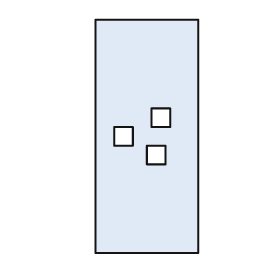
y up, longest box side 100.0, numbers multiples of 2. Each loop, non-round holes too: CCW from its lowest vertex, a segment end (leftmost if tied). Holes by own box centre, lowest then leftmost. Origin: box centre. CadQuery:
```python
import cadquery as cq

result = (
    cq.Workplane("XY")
    .moveTo(-22.0, -50.0)
    .lineTo(22.0, -50.0)
    .lineTo(22.0, 50.0)
    .lineTo(-22.0, 50.0)
    .close()
    .moveTo(0.0, -12.0)
    .lineTo(8.0, -12.0)
    .lineTo(8.0, -4.0)
    .lineTo(0.0, -4.0)
    .close()
    .moveTo(-14.0, -4.0)
    .lineTo(-6.0, -4.0)
    .lineTo(-6.0, 4.0)
    .lineTo(-14.0, 4.0)
    .close()
    .moveTo(2.0, 4.0)
    .lineTo(10.0, 4.0)
    .lineTo(10.0, 12.0)
    .lineTo(2.0, 12.0)
    .close()
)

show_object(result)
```